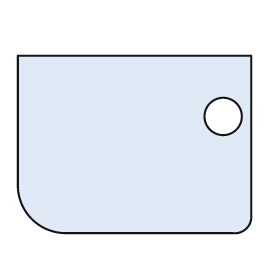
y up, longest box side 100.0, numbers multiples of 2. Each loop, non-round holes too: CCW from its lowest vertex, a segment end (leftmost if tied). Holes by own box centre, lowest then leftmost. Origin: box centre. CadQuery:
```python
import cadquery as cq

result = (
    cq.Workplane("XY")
    .moveTo(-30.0, -38.0)
    .lineTo(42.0, -38.0)
    .threePointArc((48.0, -36.0), (50.0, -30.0))
    .lineTo(50.0, 38.0)
    .lineTo(-50.0, 38.0)
    .lineTo(-50.0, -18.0)
    .threePointArc((-44.0, -32.0), (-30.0, -38.0))
    .close()
    .moveTo(38.0, 12.0)
    .circle(8.0)
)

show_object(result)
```